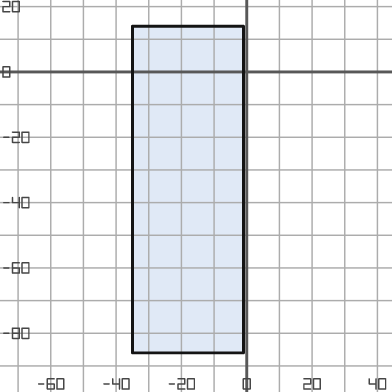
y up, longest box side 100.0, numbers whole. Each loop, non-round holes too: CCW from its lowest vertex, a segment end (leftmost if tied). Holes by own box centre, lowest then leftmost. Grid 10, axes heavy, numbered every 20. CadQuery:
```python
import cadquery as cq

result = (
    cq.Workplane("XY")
    .moveTo(-35.0, -86.0)
    .lineTo(-1.0, -86.0)
    .lineTo(-1.0, 14.0)
    .lineTo(-35.0, 14.0)
    .close()
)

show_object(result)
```